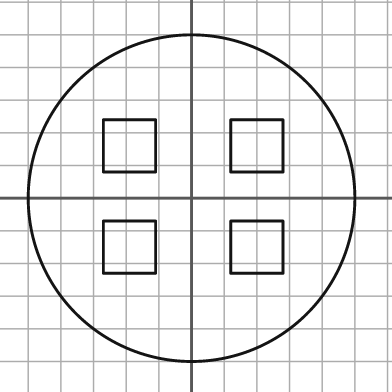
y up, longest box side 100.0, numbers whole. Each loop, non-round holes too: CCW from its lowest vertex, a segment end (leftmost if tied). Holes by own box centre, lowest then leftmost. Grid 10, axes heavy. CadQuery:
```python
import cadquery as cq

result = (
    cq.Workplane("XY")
    .moveTo(0.0, 0.0)
    .circle(50.0)
    .moveTo(-27.0, -23.0)
    .lineTo(-11.0, -23.0)
    .lineTo(-11.0, -7.0)
    .lineTo(-27.0, -7.0)
    .close()
    .moveTo(12.0, -23.0)
    .lineTo(28.0, -23.0)
    .lineTo(28.0, -7.0)
    .lineTo(12.0, -7.0)
    .close()
    .moveTo(-27.0, 8.0)
    .lineTo(-11.0, 8.0)
    .lineTo(-11.0, 24.0)
    .lineTo(-27.0, 24.0)
    .close()
    .moveTo(12.0, 8.0)
    .lineTo(28.0, 8.0)
    .lineTo(28.0, 24.0)
    .lineTo(12.0, 24.0)
    .close()
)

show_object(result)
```